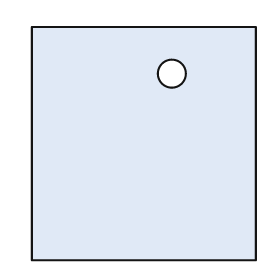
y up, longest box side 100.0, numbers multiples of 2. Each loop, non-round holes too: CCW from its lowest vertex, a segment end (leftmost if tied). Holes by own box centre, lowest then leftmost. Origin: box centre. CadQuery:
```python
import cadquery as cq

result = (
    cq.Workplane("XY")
    .moveTo(-48.0, -50.0)
    .lineTo(48.0, -50.0)
    .lineTo(48.0, 50.0)
    .lineTo(-48.0, 50.0)
    .close()
    .moveTo(12.0, 30.0)
    .circle(6.0)
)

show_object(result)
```